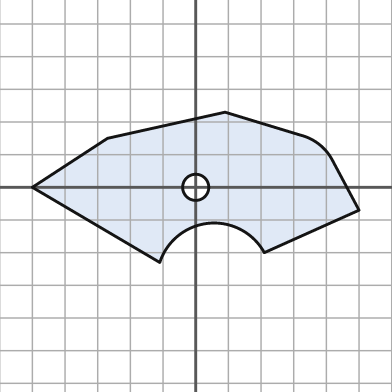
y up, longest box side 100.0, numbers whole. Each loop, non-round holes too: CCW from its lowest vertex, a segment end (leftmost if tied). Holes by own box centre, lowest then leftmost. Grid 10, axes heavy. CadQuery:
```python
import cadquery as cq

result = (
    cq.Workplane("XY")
    .moveTo(-11.0, -23.0)
    .threePointArc((4.0, -11.0), (21.0, -20.0))
    .lineTo(50.0, -7.0)
    .lineTo(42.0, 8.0)
    .threePointArc((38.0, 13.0), (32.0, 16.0))
    .lineTo(9.0, 23.0)
    .lineTo(-27.0, 15.0)
    .lineTo(-50.0, 0.0)
    .close()
    .moveTo(0.0, 0.0)
    .circle(4.0)
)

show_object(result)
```